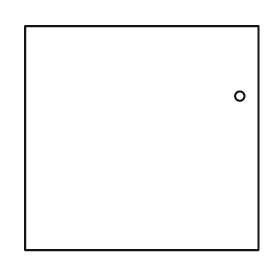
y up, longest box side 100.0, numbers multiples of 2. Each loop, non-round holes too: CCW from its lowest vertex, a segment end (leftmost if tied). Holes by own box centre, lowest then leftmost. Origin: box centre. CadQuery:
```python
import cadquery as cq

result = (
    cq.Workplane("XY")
    .moveTo(-50.0, -48.0)
    .lineTo(50.0, -48.0)
    .lineTo(50.0, 48.0)
    .lineTo(-50.0, 48.0)
    .close()
    .moveTo(42.0, 18.0)
    .circle(2.0)
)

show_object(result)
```